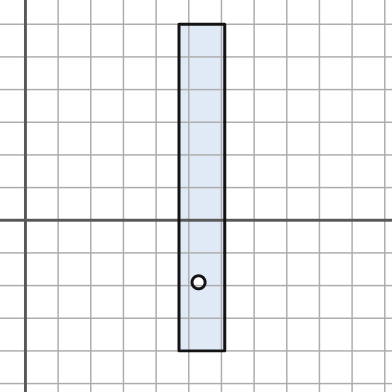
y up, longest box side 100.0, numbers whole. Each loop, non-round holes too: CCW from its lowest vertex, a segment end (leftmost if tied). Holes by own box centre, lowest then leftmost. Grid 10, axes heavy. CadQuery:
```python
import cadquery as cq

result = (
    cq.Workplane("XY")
    .moveTo(47.0, -40.0)
    .lineTo(61.0, -40.0)
    .lineTo(61.0, 60.0)
    .lineTo(47.0, 60.0)
    .close()
    .moveTo(53.0, -19.0)
    .circle(2.0)
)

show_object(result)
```